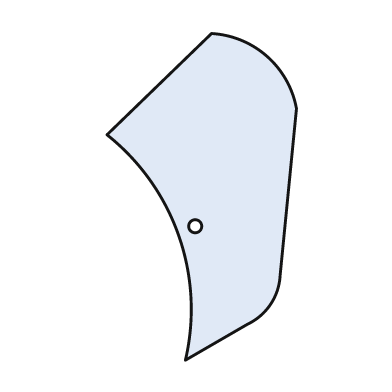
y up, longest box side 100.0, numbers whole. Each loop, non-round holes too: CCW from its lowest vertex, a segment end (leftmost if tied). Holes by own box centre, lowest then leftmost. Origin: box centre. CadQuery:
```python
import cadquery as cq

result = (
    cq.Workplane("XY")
    .moveTo(-5.0, -50.0)
    .lineTo(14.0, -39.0)
    .threePointArc((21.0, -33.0), (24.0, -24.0))
    .lineTo(29.0, 27.0)
    .threePointArc((20.0, 43.0), (3.0, 50.0))
    .lineTo(-29.0, 19.0)
    .threePointArc((-7.0, -12.0), (-5.0, -50.0))
    .close()
    .moveTo(-2.0, -9.0)
    .circle(2.0)
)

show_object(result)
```